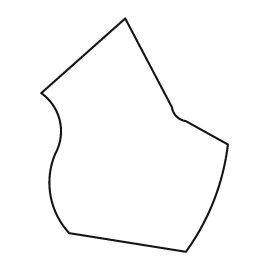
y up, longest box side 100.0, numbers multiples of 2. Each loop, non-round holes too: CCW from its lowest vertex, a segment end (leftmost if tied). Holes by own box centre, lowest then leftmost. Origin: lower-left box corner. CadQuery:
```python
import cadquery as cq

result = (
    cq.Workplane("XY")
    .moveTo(62.0, 0.0)
    .threePointArc((74.0, 22.0), (80.0, 46.0))
    .lineTo(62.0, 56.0)
    .threePointArc((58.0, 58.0), (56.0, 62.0))
    .lineTo(36.0, 100.0)
    .lineTo(0.0, 68.0)
    .threePointArc((8.0, 56.0), (6.0, 42.0))
    .threePointArc((4.0, 24.0), (12.0, 8.0))
    .close()
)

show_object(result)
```